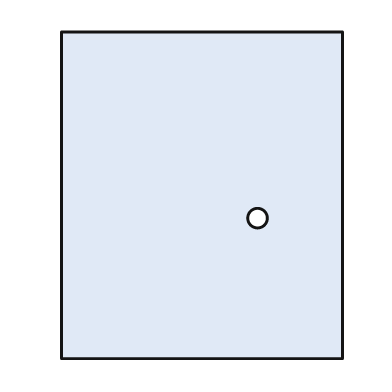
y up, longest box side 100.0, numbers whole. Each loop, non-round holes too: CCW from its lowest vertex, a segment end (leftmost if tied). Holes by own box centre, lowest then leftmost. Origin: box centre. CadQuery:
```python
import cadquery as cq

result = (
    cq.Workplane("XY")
    .moveTo(-43.0, -50.0)
    .lineTo(43.0, -50.0)
    .lineTo(43.0, 50.0)
    .lineTo(-43.0, 50.0)
    .close()
    .moveTo(17.0, -7.0)
    .circle(3.0)
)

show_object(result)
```